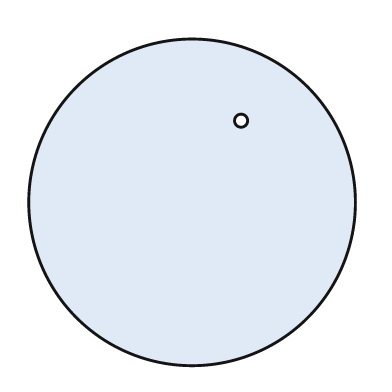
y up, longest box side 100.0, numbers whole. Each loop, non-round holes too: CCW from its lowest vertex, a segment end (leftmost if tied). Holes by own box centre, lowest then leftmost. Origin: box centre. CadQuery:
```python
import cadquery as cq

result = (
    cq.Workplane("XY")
    .moveTo(0.0, 0.0)
    .circle(50.0)
    .moveTo(15.0, 25.0)
    .circle(2.0)
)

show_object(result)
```